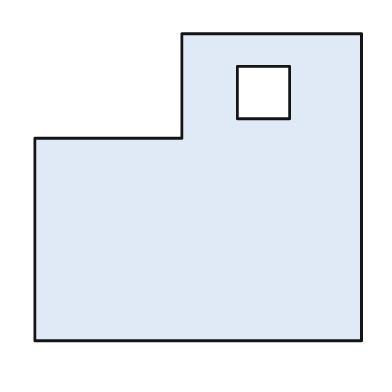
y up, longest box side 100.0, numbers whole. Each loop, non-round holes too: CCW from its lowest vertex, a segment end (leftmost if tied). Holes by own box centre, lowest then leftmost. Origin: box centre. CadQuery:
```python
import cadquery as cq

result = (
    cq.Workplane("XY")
    .moveTo(-50.0, -47.0)
    .lineTo(50.0, -47.0)
    .lineTo(50.0, 47.0)
    .lineTo(-5.0, 47.0)
    .lineTo(-5.0, 15.0)
    .lineTo(-50.0, 15.0)
    .close()
    .moveTo(12.0, 21.0)
    .lineTo(28.0, 21.0)
    .lineTo(28.0, 37.0)
    .lineTo(12.0, 37.0)
    .close()
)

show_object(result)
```